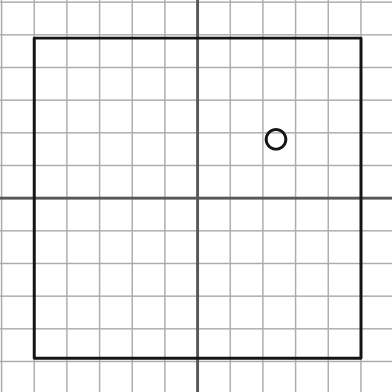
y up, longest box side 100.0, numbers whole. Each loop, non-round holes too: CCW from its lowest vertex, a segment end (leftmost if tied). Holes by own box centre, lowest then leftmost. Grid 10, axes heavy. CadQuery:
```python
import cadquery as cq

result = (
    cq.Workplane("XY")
    .moveTo(-50.0, -49.0)
    .lineTo(50.0, -49.0)
    .lineTo(50.0, 49.0)
    .lineTo(-50.0, 49.0)
    .close()
    .moveTo(24.0, 18.0)
    .circle(3.0)
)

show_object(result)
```